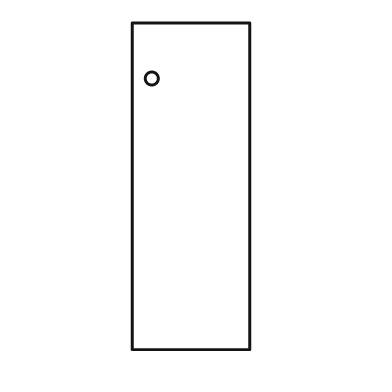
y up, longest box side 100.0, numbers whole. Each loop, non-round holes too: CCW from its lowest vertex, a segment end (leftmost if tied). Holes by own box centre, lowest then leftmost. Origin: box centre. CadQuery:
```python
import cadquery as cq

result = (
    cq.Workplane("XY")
    .moveTo(-18.0, -50.0)
    .lineTo(18.0, -50.0)
    .lineTo(18.0, 50.0)
    .lineTo(-18.0, 50.0)
    .close()
    .moveTo(-12.0, 33.0)
    .circle(2.0)
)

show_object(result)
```